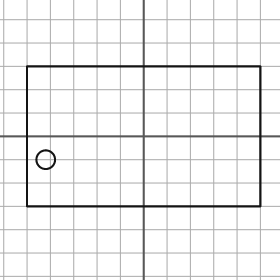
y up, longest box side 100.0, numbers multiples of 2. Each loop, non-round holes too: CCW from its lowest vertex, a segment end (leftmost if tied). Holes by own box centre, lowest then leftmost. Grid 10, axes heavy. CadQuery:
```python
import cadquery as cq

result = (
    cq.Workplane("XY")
    .moveTo(-50.0, -30.0)
    .lineTo(50.0, -30.0)
    .lineTo(50.0, 30.0)
    .lineTo(-50.0, 30.0)
    .close()
    .moveTo(-42.0, -10.0)
    .circle(4.0)
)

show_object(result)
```